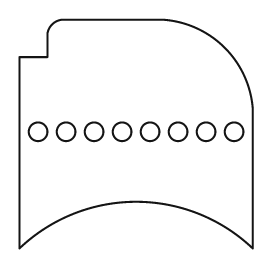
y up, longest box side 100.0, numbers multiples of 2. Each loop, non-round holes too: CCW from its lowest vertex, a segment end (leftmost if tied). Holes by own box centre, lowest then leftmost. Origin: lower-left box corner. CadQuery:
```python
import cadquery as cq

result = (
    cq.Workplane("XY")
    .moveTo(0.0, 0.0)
    .threePointArc((50.0, 20.0), (100.0, 0.0))
    .lineTo(100.0, 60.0)
    .threePointArc((88.0, 86.0), (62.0, 98.0))
    .lineTo(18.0, 98.0)
    .threePointArc((14.0, 96.0), (12.0, 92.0))
    .lineTo(12.0, 82.0)
    .lineTo(0.0, 82.0)
    .close()
    .moveTo(8.0, 50.0)
    .circle(4.0)
    .moveTo(20.0, 50.0)
    .circle(4.0)
    .moveTo(32.0, 50.0)
    .circle(4.0)
    .moveTo(44.0, 50.0)
    .circle(4.0)
    .moveTo(56.0, 50.0)
    .circle(4.0)
    .moveTo(68.0, 50.0)
    .circle(4.0)
    .moveTo(80.0, 50.0)
    .circle(4.0)
    .moveTo(92.0, 50.0)
    .circle(4.0)
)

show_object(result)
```